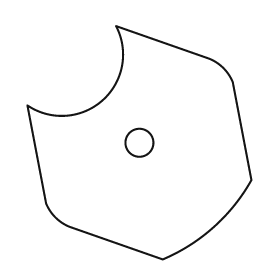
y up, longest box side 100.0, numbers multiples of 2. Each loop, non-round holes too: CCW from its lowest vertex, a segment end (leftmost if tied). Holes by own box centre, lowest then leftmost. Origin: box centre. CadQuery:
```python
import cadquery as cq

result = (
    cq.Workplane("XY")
    .moveTo(10.0, -50.0)
    .threePointArc((32.0, -36.0), (48.0, -16.0))
    .lineTo(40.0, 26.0)
    .threePointArc((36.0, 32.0), (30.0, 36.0))
    .lineTo(-10.0, 50.0)
    .threePointArc((-16.0, 18.0), (-48.0, 16.0))
    .lineTo(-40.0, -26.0)
    .threePointArc((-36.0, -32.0), (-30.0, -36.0))
    .close()
    .moveTo(0.0, 0.0)
    .circle(6.0)
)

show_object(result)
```